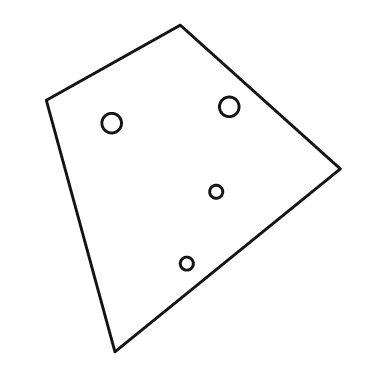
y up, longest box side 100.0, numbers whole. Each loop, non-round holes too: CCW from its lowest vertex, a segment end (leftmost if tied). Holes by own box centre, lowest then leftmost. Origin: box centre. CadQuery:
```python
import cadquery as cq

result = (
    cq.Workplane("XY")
    .moveTo(-24.0, -50.0)
    .lineTo(45.0, 6.0)
    .lineTo(-4.0, 50.0)
    .lineTo(-45.0, 27.0)
    .close()
    .moveTo(-2.0, -23.0)
    .circle(2.0)
    .moveTo(7.0, -1.0)
    .circle(2.0)
    .moveTo(-25.0, 20.0)
    .circle(3.0)
    .moveTo(11.0, 25.0)
    .circle(3.0)
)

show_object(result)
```